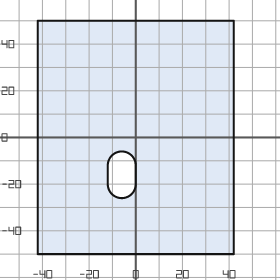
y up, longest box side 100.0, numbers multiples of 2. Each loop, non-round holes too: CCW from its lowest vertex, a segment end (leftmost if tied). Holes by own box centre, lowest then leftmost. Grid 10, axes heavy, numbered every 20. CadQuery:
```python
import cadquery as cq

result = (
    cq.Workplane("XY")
    .moveTo(-42.0, -50.0)
    .lineTo(42.0, -50.0)
    .lineTo(42.0, 50.0)
    .lineTo(-42.0, 50.0)
    .close()
    .moveTo(-12.0, -20.0)
    .threePointArc((-6.0, -26.0), (0.0, -20.0))
    .lineTo(0.0, -12.0)
    .threePointArc((-6.0, -6.0), (-12.0, -12.0))
    .close()
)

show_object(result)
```